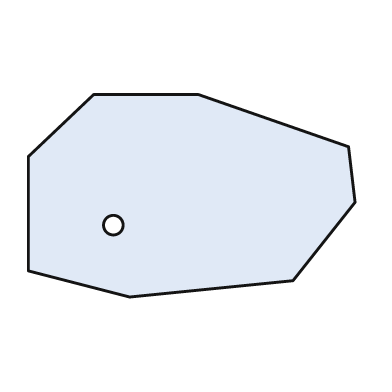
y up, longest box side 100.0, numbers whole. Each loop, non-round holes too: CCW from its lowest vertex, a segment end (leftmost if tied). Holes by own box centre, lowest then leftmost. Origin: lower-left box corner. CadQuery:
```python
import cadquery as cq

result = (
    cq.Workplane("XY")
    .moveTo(31.0, 0.0)
    .lineTo(81.0, 5.0)
    .lineTo(100.0, 29.0)
    .lineTo(98.0, 46.0)
    .lineTo(52.0, 62.0)
    .lineTo(20.0, 62.0)
    .lineTo(0.0, 43.0)
    .lineTo(0.0, 8.0)
    .close()
    .moveTo(26.0, 22.0)
    .circle(3.0)
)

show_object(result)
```